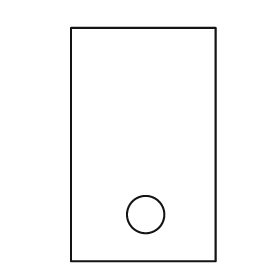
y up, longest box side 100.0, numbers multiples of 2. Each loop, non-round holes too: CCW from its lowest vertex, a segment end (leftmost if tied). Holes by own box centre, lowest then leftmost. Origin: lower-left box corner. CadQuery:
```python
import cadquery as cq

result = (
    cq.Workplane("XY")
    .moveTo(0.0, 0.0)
    .lineTo(62.0, 0.0)
    .lineTo(62.0, 100.0)
    .lineTo(0.0, 100.0)
    .close()
    .moveTo(32.0, 20.0)
    .circle(8.0)
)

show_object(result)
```